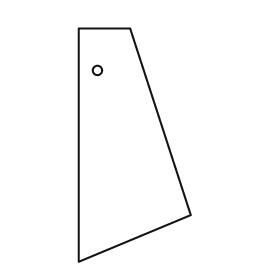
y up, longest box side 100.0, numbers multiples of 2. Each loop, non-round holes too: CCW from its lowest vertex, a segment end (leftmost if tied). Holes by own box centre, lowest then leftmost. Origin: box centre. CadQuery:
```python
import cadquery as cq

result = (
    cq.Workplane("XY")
    .moveTo(-24.0, -50.0)
    .lineTo(24.0, -30.0)
    .lineTo(-2.0, 50.0)
    .lineTo(-24.0, 50.0)
    .close()
    .moveTo(-16.0, 32.0)
    .circle(2.0)
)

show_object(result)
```